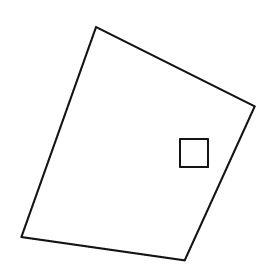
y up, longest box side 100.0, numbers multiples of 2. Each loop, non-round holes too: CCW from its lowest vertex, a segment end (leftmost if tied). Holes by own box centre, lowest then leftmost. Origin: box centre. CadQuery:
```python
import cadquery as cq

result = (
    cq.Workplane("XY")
    .moveTo(20.0, -50.0)
    .lineTo(50.0, 16.0)
    .lineTo(-18.0, 50.0)
    .lineTo(-50.0, -40.0)
    .close()
    .moveTo(18.0, -10.0)
    .lineTo(30.0, -10.0)
    .lineTo(30.0, 2.0)
    .lineTo(18.0, 2.0)
    .close()
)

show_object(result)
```